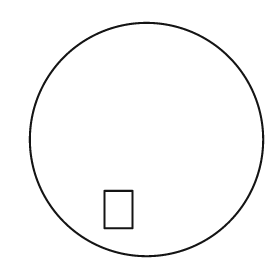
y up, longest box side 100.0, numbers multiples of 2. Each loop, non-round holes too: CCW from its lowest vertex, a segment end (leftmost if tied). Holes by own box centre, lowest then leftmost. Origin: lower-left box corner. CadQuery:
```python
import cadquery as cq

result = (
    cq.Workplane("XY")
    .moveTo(50.0, 50.0)
    .circle(50.0)
    .moveTo(32.0, 12.0)
    .lineTo(44.0, 12.0)
    .lineTo(44.0, 28.0)
    .lineTo(32.0, 28.0)
    .close()
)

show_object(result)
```